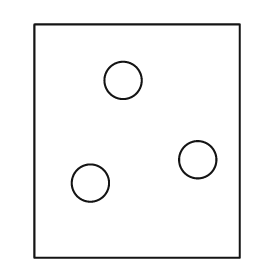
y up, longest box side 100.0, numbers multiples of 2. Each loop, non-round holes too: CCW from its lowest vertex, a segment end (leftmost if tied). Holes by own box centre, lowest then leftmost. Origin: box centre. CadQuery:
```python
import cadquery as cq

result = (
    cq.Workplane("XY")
    .moveTo(-44.0, -50.0)
    .lineTo(44.0, -50.0)
    .lineTo(44.0, 50.0)
    .lineTo(-44.0, 50.0)
    .close()
    .moveTo(-20.0, -18.0)
    .circle(8.0)
    .moveTo(26.0, -8.0)
    .circle(8.0)
    .moveTo(-6.0, 26.0)
    .circle(8.0)
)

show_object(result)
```